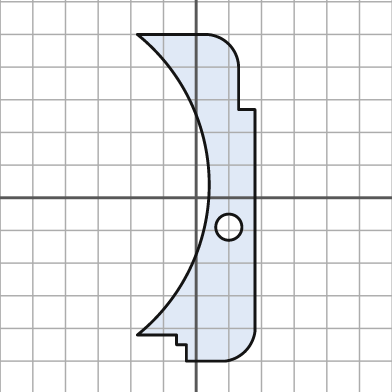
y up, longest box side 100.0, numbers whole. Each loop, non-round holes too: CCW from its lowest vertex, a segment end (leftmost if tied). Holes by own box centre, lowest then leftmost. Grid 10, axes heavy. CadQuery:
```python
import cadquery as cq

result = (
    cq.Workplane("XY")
    .moveTo(-3.0, -50.0)
    .lineTo(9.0, -50.0)
    .threePointArc((15.0, -47.0), (18.0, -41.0))
    .lineTo(18.0, 27.0)
    .lineTo(13.0, 27.0)
    .lineTo(13.0, 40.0)
    .threePointArc((10.0, 47.0), (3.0, 50.0))
    .lineTo(-18.0, 50.0)
    .threePointArc((4.0, 4.0), (-18.0, -42.0))
    .lineTo(-6.0, -42.0)
    .lineTo(-6.0, -45.0)
    .lineTo(-3.0, -45.0)
    .close()
    .moveTo(10.0, -9.0)
    .circle(4.0)
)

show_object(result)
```